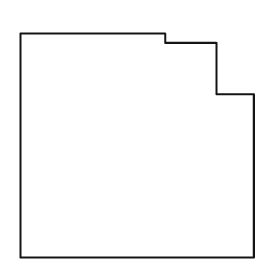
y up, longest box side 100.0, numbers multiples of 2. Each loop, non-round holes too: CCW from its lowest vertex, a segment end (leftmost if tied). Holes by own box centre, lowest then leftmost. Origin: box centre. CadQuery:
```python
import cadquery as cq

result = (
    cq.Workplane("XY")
    .moveTo(-50.0, -48.0)
    .lineTo(50.0, -48.0)
    .lineTo(50.0, 22.0)
    .lineTo(34.0, 22.0)
    .lineTo(34.0, 44.0)
    .lineTo(12.0, 44.0)
    .lineTo(12.0, 48.0)
    .lineTo(-50.0, 48.0)
    .close()
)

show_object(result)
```